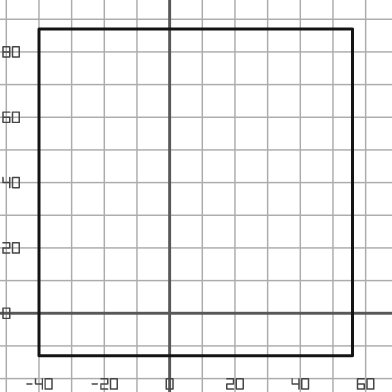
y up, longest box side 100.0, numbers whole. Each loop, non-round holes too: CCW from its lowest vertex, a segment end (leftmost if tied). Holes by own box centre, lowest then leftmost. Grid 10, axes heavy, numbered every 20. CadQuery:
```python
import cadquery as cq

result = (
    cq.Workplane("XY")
    .moveTo(-40.0, -13.0)
    .lineTo(56.0, -13.0)
    .lineTo(56.0, 87.0)
    .lineTo(-40.0, 87.0)
    .close()
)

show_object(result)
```